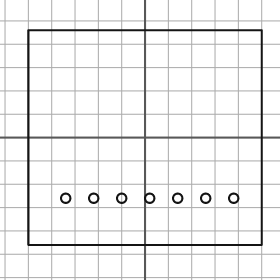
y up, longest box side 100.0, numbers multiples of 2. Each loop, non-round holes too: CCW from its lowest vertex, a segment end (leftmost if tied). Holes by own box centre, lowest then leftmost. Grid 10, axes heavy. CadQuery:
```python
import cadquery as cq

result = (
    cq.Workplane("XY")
    .moveTo(-50.0, -46.0)
    .lineTo(50.0, -46.0)
    .lineTo(50.0, 46.0)
    .lineTo(-50.0, 46.0)
    .close()
    .moveTo(-34.0, -26.0)
    .circle(2.0)
    .moveTo(-22.0, -26.0)
    .circle(2.0)
    .moveTo(-10.0, -26.0)
    .circle(2.0)
    .moveTo(2.0, -26.0)
    .circle(2.0)
    .moveTo(14.0, -26.0)
    .circle(2.0)
    .moveTo(26.0, -26.0)
    .circle(2.0)
    .moveTo(38.0, -26.0)
    .circle(2.0)
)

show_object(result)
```